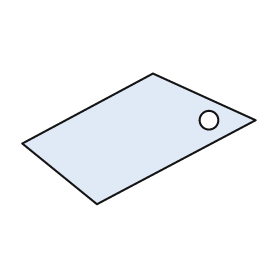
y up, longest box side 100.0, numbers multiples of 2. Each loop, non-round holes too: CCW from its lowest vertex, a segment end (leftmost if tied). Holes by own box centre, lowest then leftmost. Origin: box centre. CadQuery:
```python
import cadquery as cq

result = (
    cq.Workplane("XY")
    .moveTo(-18.0, -28.0)
    .lineTo(50.0, 8.0)
    .lineTo(6.0, 28.0)
    .lineTo(-50.0, -2.0)
    .close()
    .moveTo(30.0, 8.0)
    .circle(4.0)
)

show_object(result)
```